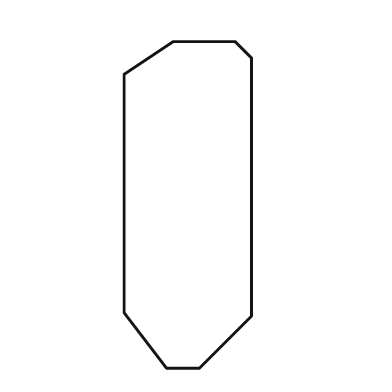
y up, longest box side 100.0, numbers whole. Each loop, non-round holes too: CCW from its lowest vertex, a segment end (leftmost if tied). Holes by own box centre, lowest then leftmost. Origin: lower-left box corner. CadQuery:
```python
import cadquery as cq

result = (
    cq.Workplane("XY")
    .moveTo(13.0, 0.0)
    .lineTo(23.0, 0.0)
    .lineTo(39.0, 16.0)
    .lineTo(39.0, 95.0)
    .lineTo(34.0, 100.0)
    .lineTo(15.0, 100.0)
    .lineTo(0.0, 90.0)
    .lineTo(0.0, 17.0)
    .close()
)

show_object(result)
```